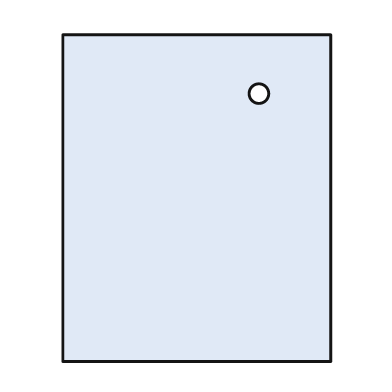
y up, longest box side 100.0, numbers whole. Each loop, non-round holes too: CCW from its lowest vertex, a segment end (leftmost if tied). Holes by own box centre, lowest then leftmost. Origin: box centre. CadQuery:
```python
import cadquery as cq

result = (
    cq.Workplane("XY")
    .moveTo(-41.0, -50.0)
    .lineTo(41.0, -50.0)
    .lineTo(41.0, 50.0)
    .lineTo(-41.0, 50.0)
    .close()
    .moveTo(19.0, 32.0)
    .circle(3.0)
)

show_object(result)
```